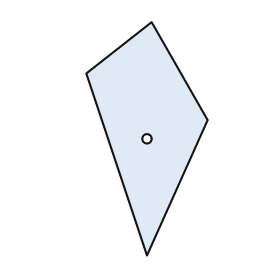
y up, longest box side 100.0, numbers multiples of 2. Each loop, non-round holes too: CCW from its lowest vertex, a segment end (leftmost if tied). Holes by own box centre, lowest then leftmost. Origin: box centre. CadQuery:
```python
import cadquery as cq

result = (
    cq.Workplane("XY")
    .moveTo(0.0, -50.0)
    .lineTo(26.0, 8.0)
    .lineTo(2.0, 50.0)
    .lineTo(-26.0, 28.0)
    .close()
    .moveTo(0.0, 0.0)
    .circle(2.0)
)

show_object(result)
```